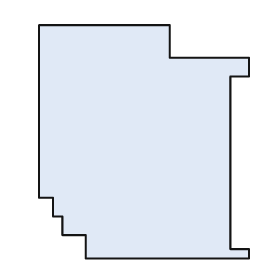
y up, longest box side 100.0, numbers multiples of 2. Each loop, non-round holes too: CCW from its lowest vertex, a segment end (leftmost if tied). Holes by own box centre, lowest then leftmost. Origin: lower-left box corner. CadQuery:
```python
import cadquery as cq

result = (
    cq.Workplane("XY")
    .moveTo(20.0, 0.0)
    .lineTo(90.0, 0.0)
    .lineTo(90.0, 4.0)
    .lineTo(82.0, 4.0)
    .lineTo(82.0, 78.0)
    .lineTo(90.0, 78.0)
    .lineTo(90.0, 86.0)
    .lineTo(56.0, 86.0)
    .lineTo(56.0, 100.0)
    .lineTo(0.0, 100.0)
    .lineTo(0.0, 26.0)
    .lineTo(6.0, 26.0)
    .lineTo(6.0, 18.0)
    .lineTo(10.0, 18.0)
    .lineTo(10.0, 10.0)
    .lineTo(20.0, 10.0)
    .close()
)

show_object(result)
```